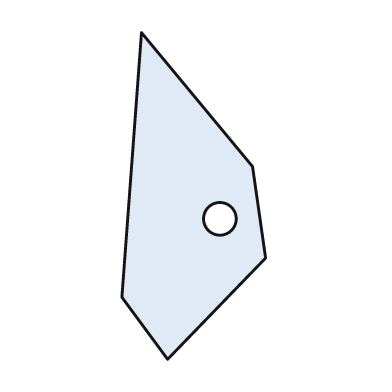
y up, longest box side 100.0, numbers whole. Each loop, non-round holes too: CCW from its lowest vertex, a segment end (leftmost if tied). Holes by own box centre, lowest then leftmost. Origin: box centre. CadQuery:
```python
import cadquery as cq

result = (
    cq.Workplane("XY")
    .moveTo(-8.0, -50.0)
    .lineTo(22.0, -19.0)
    .lineTo(18.0, 9.0)
    .lineTo(-16.0, 50.0)
    .lineTo(-22.0, -31.0)
    .close()
    .moveTo(8.0, -7.0)
    .circle(5.0)
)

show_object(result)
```